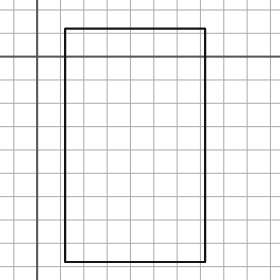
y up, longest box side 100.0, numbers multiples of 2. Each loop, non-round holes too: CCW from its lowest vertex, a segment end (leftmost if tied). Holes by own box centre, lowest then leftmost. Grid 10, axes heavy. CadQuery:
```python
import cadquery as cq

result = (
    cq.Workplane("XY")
    .moveTo(12.0, -88.0)
    .lineTo(72.0, -88.0)
    .lineTo(72.0, 12.0)
    .lineTo(12.0, 12.0)
    .close()
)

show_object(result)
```